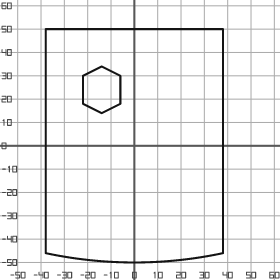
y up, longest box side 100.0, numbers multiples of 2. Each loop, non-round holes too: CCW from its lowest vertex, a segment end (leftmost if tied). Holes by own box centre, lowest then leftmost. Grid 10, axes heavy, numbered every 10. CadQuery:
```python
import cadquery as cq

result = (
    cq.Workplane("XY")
    .moveTo(-38.0, -46.0)
    .threePointArc((0.0, -50.0), (38.0, -46.0))
    .lineTo(38.0, 50.0)
    .lineTo(-38.0, 50.0)
    .close()
    .moveTo(-14.0, 14.0)
    .lineTo(-6.0, 18.0)
    .lineTo(-6.0, 30.0)
    .lineTo(-14.0, 34.0)
    .lineTo(-22.0, 30.0)
    .lineTo(-22.0, 18.0)
    .close()
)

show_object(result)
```